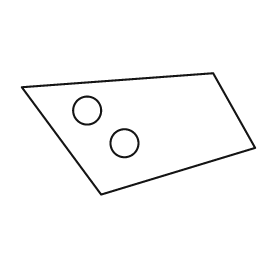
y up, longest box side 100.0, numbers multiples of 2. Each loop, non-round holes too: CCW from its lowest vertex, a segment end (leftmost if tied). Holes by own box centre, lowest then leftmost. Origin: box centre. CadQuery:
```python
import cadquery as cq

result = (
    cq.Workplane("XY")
    .moveTo(-16.0, -26.0)
    .lineTo(50.0, -6.0)
    .lineTo(32.0, 26.0)
    .lineTo(-50.0, 20.0)
    .close()
    .moveTo(-6.0, -4.0)
    .circle(6.0)
    .moveTo(-22.0, 10.0)
    .circle(6.0)
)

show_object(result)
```